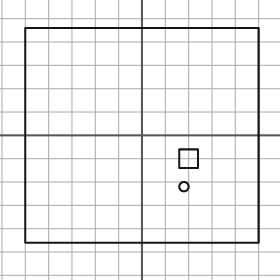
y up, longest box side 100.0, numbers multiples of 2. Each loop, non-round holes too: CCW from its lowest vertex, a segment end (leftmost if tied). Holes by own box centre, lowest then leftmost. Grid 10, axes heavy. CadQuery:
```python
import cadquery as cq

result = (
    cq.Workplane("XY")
    .moveTo(-50.0, -46.0)
    .lineTo(50.0, -46.0)
    .lineTo(50.0, 46.0)
    .lineTo(-50.0, 46.0)
    .close()
    .moveTo(18.0, -22.0)
    .circle(2.0)
    .moveTo(16.0, -14.0)
    .lineTo(24.0, -14.0)
    .lineTo(24.0, -6.0)
    .lineTo(16.0, -6.0)
    .close()
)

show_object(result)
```